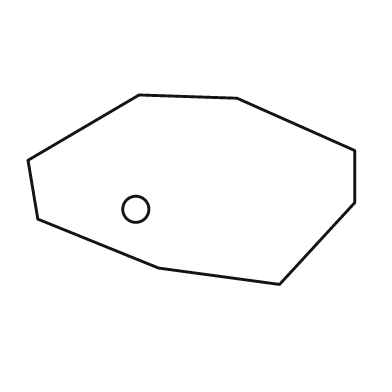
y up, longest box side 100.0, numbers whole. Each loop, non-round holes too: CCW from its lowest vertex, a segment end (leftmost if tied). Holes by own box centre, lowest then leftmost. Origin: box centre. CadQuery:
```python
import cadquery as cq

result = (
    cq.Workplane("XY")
    .moveTo(27.0, -29.0)
    .lineTo(50.0, -4.0)
    .lineTo(50.0, 12.0)
    .lineTo(14.0, 28.0)
    .lineTo(-16.0, 29.0)
    .lineTo(-50.0, 9.0)
    .lineTo(-47.0, -9.0)
    .lineTo(-10.0, -24.0)
    .close()
    .moveTo(-17.0, -6.0)
    .circle(4.0)
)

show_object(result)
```